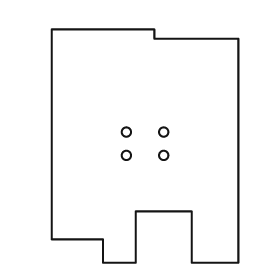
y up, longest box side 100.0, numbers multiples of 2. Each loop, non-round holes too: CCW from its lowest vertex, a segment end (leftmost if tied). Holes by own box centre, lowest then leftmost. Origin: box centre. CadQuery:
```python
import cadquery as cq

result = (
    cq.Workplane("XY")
    .moveTo(-18.0, -50.0)
    .lineTo(-4.0, -50.0)
    .lineTo(-4.0, -28.0)
    .lineTo(20.0, -28.0)
    .lineTo(20.0, -50.0)
    .lineTo(40.0, -50.0)
    .lineTo(40.0, 46.0)
    .lineTo(4.0, 46.0)
    .lineTo(4.0, 50.0)
    .lineTo(-40.0, 50.0)
    .lineTo(-40.0, -40.0)
    .lineTo(-18.0, -40.0)
    .close()
    .moveTo(-8.0, -4.0)
    .circle(2.0)
    .moveTo(8.0, -4.0)
    .circle(2.0)
    .moveTo(-8.0, 6.0)
    .circle(2.0)
    .moveTo(8.0, 6.0)
    .circle(2.0)
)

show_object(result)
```